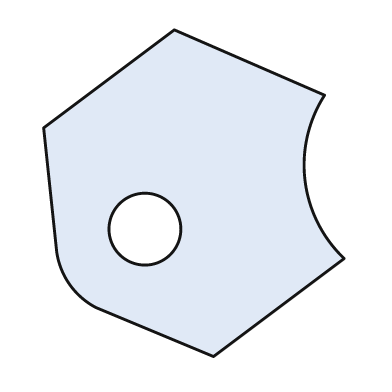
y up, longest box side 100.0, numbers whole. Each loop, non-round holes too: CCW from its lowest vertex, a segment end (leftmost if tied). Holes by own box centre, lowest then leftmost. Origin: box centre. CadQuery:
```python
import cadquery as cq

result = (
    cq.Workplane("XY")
    .moveTo(6.0, -50.0)
    .lineTo(46.0, -20.0)
    .threePointArc((34.0, 4.0), (40.0, 30.0))
    .lineTo(-6.0, 50.0)
    .lineTo(-46.0, 20.0)
    .lineTo(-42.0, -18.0)
    .threePointArc((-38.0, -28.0), (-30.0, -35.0))
    .close()
    .moveTo(-15.0, -11.0)
    .circle(11.0)
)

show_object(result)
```